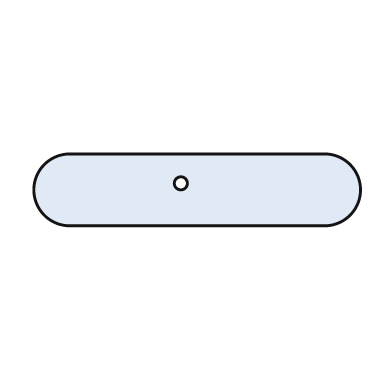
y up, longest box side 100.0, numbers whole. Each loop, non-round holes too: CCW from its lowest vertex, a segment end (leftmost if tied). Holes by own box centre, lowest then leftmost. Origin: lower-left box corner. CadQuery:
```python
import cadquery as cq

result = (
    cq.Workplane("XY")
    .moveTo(11.0, 0.0)
    .lineTo(89.0, 0.0)
    .threePointArc((100.0, 11.0), (89.0, 22.0))
    .lineTo(11.0, 22.0)
    .threePointArc((0.0, 11.0), (11.0, 0.0))
    .close()
    .moveTo(45.0, 13.0)
    .circle(2.0)
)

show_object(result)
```